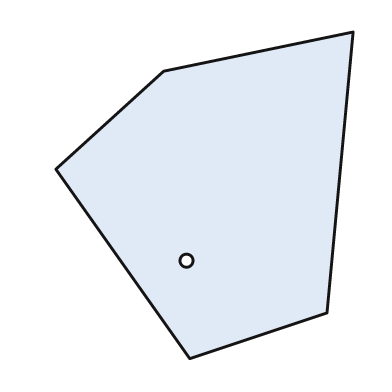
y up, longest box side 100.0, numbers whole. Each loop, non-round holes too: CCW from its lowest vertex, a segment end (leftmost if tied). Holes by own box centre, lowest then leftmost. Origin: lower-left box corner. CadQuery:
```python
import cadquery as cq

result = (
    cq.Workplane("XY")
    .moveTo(41.0, 0.0)
    .lineTo(83.0, 14.0)
    .lineTo(91.0, 100.0)
    .lineTo(33.0, 88.0)
    .lineTo(0.0, 58.0)
    .close()
    .moveTo(40.0, 30.0)
    .circle(2.0)
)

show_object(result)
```